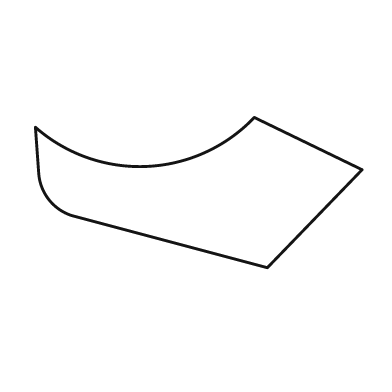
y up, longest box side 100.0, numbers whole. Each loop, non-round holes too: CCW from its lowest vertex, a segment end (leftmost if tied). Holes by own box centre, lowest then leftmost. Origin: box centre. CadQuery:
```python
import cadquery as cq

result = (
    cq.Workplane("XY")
    .moveTo(21.0, -23.0)
    .lineTo(50.0, 7.0)
    .lineTo(17.0, 23.0)
    .threePointArc((-16.0, 8.0), (-50.0, 20.0))
    .lineTo(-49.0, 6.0)
    .threePointArc((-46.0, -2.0), (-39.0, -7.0))
    .close()
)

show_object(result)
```